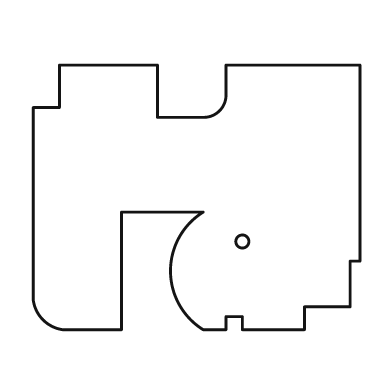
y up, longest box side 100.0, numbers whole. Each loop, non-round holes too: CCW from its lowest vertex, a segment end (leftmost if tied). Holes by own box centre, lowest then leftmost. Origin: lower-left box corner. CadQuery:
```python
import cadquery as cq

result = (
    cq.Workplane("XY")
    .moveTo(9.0, 0.0)
    .lineTo(27.0, 0.0)
    .lineTo(27.0, 36.0)
    .lineTo(52.0, 36.0)
    .threePointArc((42.0, 18.0), (52.0, 0.0))
    .lineTo(59.0, 0.0)
    .lineTo(59.0, 4.0)
    .lineTo(64.0, 4.0)
    .lineTo(64.0, 0.0)
    .lineTo(83.0, 0.0)
    .lineTo(83.0, 7.0)
    .lineTo(97.0, 7.0)
    .lineTo(97.0, 21.0)
    .lineTo(100.0, 21.0)
    .lineTo(100.0, 81.0)
    .lineTo(59.0, 81.0)
    .lineTo(59.0, 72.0)
    .threePointArc((57.0, 67.0), (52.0, 65.0))
    .lineTo(38.0, 65.0)
    .lineTo(38.0, 81.0)
    .lineTo(8.0, 81.0)
    .lineTo(8.0, 68.0)
    .lineTo(0.0, 68.0)
    .lineTo(0.0, 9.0)
    .threePointArc((3.0, 3.0), (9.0, 0.0))
    .close()
    .moveTo(64.0, 27.0)
    .circle(2.0)
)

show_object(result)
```